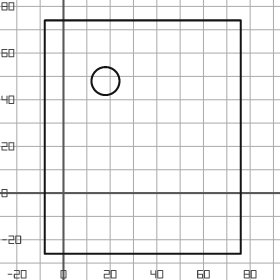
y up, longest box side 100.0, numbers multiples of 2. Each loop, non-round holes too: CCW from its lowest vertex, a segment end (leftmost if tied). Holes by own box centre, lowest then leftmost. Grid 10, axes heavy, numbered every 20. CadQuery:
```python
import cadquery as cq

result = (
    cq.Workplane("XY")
    .moveTo(-8.0, -26.0)
    .lineTo(76.0, -26.0)
    .lineTo(76.0, 74.0)
    .lineTo(-8.0, 74.0)
    .close()
    .moveTo(18.0, 48.0)
    .circle(6.0)
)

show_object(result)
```